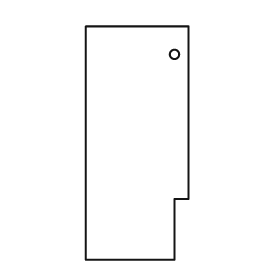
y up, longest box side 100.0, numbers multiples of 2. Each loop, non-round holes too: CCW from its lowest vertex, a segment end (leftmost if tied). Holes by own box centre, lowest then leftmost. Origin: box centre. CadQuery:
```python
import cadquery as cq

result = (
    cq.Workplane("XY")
    .moveTo(-22.0, -50.0)
    .lineTo(16.0, -50.0)
    .lineTo(16.0, -24.0)
    .lineTo(22.0, -24.0)
    .lineTo(22.0, 50.0)
    .lineTo(-22.0, 50.0)
    .close()
    .moveTo(16.0, 38.0)
    .circle(2.0)
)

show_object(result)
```